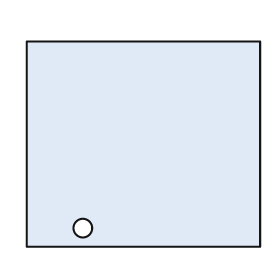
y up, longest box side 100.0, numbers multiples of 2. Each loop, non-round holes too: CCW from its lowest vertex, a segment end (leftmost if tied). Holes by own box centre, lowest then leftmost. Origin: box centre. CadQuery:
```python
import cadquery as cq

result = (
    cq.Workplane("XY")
    .moveTo(-50.0, -44.0)
    .lineTo(50.0, -44.0)
    .lineTo(50.0, 44.0)
    .lineTo(-50.0, 44.0)
    .close()
    .moveTo(-26.0, -36.0)
    .circle(4.0)
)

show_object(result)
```